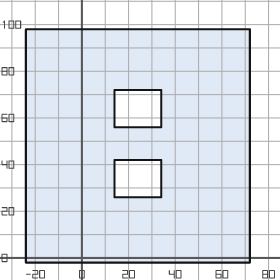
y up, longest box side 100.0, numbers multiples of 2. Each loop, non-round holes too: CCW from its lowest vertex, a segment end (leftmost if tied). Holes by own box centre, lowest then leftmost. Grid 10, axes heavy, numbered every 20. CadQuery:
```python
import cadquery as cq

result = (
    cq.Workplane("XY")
    .moveTo(-24.0, -2.0)
    .lineTo(72.0, -2.0)
    .lineTo(72.0, 98.0)
    .lineTo(-24.0, 98.0)
    .close()
    .moveTo(14.0, 26.0)
    .lineTo(34.0, 26.0)
    .lineTo(34.0, 42.0)
    .lineTo(14.0, 42.0)
    .close()
    .moveTo(14.0, 56.0)
    .lineTo(34.0, 56.0)
    .lineTo(34.0, 72.0)
    .lineTo(14.0, 72.0)
    .close()
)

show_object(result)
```